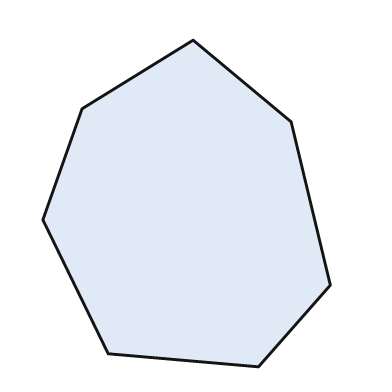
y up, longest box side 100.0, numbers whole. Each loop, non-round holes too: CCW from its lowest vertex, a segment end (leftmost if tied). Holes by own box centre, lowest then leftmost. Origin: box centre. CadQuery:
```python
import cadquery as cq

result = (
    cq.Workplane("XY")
    .moveTo(22.0, -50.0)
    .lineTo(44.0, -25.0)
    .lineTo(32.0, 25.0)
    .lineTo(2.0, 50.0)
    .lineTo(-32.0, 29.0)
    .lineTo(-44.0, -5.0)
    .lineTo(-24.0, -46.0)
    .close()
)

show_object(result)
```